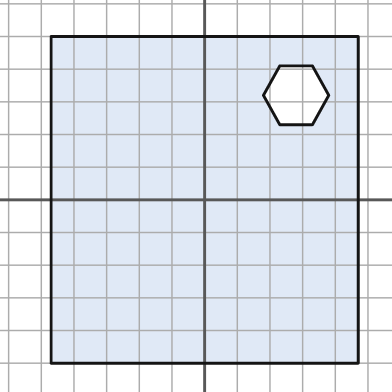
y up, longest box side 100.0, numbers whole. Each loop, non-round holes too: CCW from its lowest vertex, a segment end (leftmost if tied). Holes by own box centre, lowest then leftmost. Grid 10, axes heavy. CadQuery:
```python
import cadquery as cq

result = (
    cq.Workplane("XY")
    .moveTo(-47.0, -50.0)
    .lineTo(47.0, -50.0)
    .lineTo(47.0, 50.0)
    .lineTo(-47.0, 50.0)
    .close()
    .moveTo(23.0, 23.0)
    .lineTo(33.0, 23.0)
    .lineTo(38.0, 32.0)
    .lineTo(33.0, 41.0)
    .lineTo(23.0, 41.0)
    .lineTo(18.0, 32.0)
    .close()
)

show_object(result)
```